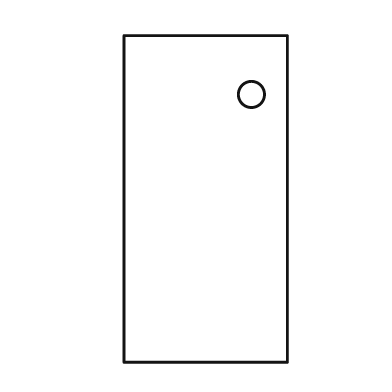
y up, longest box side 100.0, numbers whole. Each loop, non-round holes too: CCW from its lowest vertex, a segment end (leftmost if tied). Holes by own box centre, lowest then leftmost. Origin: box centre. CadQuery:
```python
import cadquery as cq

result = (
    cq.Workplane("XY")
    .moveTo(-25.0, -50.0)
    .lineTo(25.0, -50.0)
    .lineTo(25.0, 50.0)
    .lineTo(-25.0, 50.0)
    .close()
    .moveTo(14.0, 32.0)
    .circle(4.0)
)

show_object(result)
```